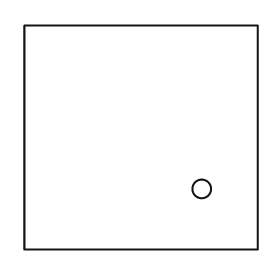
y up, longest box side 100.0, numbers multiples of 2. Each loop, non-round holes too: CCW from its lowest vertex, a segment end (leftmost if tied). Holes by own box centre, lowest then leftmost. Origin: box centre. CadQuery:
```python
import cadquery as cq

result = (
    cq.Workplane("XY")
    .moveTo(-50.0, -48.0)
    .lineTo(50.0, -48.0)
    .lineTo(50.0, 48.0)
    .lineTo(-50.0, 48.0)
    .close()
    .moveTo(26.0, -22.0)
    .circle(4.0)
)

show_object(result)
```